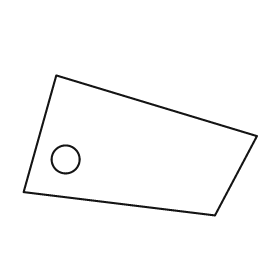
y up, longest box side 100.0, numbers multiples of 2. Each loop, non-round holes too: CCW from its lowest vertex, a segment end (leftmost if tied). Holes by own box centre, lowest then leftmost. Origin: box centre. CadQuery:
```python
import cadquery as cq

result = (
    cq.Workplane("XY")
    .moveTo(32.0, -30.0)
    .lineTo(50.0, 4.0)
    .lineTo(-36.0, 30.0)
    .lineTo(-50.0, -20.0)
    .close()
    .moveTo(-32.0, -6.0)
    .circle(6.0)
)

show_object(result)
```